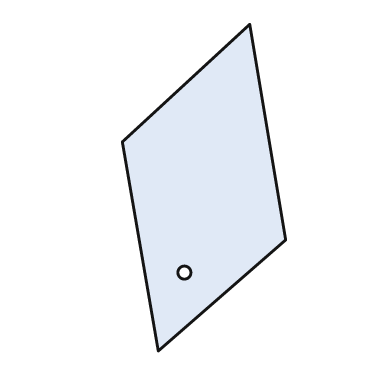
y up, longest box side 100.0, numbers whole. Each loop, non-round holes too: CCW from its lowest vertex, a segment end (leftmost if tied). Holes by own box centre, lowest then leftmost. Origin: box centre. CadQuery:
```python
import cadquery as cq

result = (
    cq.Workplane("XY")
    .moveTo(-14.0, -50.0)
    .lineTo(25.0, -16.0)
    .lineTo(14.0, 50.0)
    .lineTo(-25.0, 14.0)
    .close()
    .moveTo(-6.0, -26.0)
    .circle(2.0)
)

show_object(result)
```